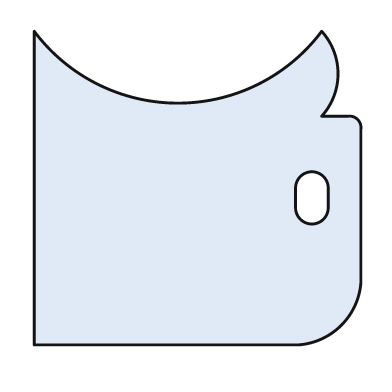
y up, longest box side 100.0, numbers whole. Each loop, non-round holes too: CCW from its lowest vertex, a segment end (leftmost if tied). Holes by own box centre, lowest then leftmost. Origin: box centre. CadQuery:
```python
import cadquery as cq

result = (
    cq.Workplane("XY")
    .moveTo(-50.0, -48.0)
    .lineTo(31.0, -48.0)
    .threePointArc((44.0, -42.0), (50.0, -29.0))
    .lineTo(50.0, 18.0)
    .threePointArc((49.0, 21.0), (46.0, 22.0))
    .lineTo(38.0, 22.0)
    .threePointArc((43.0, 35.0), (38.0, 48.0))
    .threePointArc((-6.0, 26.0), (-50.0, 48.0))
    .close()
    .moveTo(30.0, -6.0)
    .threePointArc((35.0, -11.0), (40.0, -6.0))
    .lineTo(40.0, 0.0)
    .threePointArc((35.0, 5.0), (30.0, 0.0))
    .close()
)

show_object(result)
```